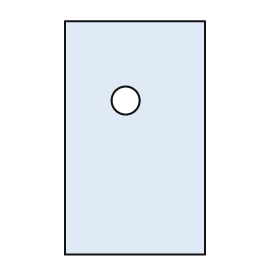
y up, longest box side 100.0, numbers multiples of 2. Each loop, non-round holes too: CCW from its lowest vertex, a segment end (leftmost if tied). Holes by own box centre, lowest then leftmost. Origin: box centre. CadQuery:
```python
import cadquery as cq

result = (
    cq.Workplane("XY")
    .moveTo(-30.0, -50.0)
    .lineTo(30.0, -50.0)
    .lineTo(30.0, 50.0)
    .lineTo(-30.0, 50.0)
    .close()
    .moveTo(-4.0, 16.0)
    .circle(6.0)
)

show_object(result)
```